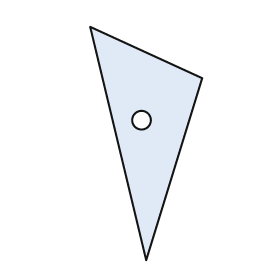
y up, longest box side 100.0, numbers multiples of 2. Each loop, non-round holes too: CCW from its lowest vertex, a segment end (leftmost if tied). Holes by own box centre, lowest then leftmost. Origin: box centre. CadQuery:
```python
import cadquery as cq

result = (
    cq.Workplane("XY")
    .moveTo(0.0, -50.0)
    .lineTo(24.0, 28.0)
    .lineTo(-24.0, 50.0)
    .close()
    .moveTo(-2.0, 10.0)
    .circle(4.0)
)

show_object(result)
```